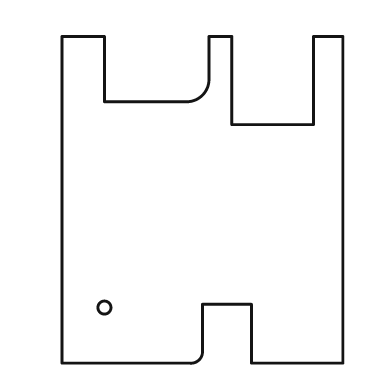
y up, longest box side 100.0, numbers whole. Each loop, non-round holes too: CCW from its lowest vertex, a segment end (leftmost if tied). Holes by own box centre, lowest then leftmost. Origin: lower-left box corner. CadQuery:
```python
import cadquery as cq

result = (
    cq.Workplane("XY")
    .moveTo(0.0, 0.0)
    .lineTo(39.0, 0.0)
    .threePointArc((42.0, 1.0), (43.0, 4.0))
    .lineTo(43.0, 18.0)
    .lineTo(58.0, 18.0)
    .lineTo(58.0, 0.0)
    .lineTo(86.0, 0.0)
    .lineTo(86.0, 100.0)
    .lineTo(77.0, 100.0)
    .lineTo(77.0, 73.0)
    .lineTo(52.0, 73.0)
    .lineTo(52.0, 100.0)
    .lineTo(45.0, 100.0)
    .lineTo(45.0, 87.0)
    .threePointArc((43.0, 82.0), (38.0, 80.0))
    .lineTo(13.0, 80.0)
    .lineTo(13.0, 100.0)
    .lineTo(0.0, 100.0)
    .close()
    .moveTo(13.0, 17.0)
    .circle(2.0)
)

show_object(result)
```